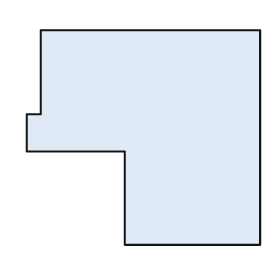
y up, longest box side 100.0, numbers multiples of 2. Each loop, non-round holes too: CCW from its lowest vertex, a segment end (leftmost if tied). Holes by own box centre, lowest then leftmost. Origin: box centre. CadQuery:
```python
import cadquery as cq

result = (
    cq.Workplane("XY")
    .moveTo(-8.0, -46.0)
    .lineTo(50.0, -46.0)
    .lineTo(50.0, 46.0)
    .lineTo(-44.0, 46.0)
    .lineTo(-44.0, 10.0)
    .lineTo(-50.0, 10.0)
    .lineTo(-50.0, -6.0)
    .lineTo(-8.0, -6.0)
    .close()
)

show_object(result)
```